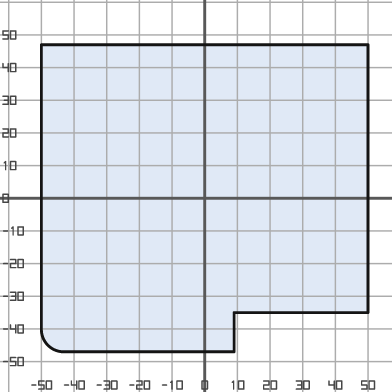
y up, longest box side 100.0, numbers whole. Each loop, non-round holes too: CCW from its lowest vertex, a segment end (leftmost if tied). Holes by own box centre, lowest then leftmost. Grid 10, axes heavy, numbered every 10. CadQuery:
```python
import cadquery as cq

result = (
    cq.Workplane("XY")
    .moveTo(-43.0, -47.0)
    .lineTo(9.0, -47.0)
    .lineTo(9.0, -35.0)
    .lineTo(50.0, -35.0)
    .lineTo(50.0, 47.0)
    .lineTo(-50.0, 47.0)
    .lineTo(-50.0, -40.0)
    .threePointArc((-48.0, -45.0), (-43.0, -47.0))
    .close()
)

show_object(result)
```